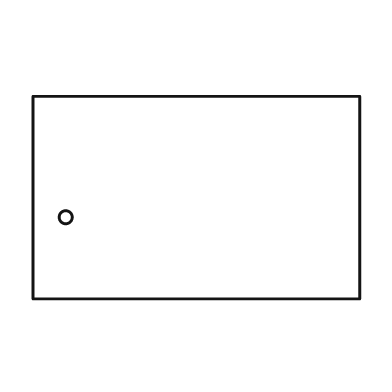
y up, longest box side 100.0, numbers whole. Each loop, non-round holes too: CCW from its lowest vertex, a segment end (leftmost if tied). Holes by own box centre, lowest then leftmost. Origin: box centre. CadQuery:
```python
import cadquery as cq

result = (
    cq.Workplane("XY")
    .moveTo(-50.0, -31.0)
    .lineTo(50.0, -31.0)
    .lineTo(50.0, 31.0)
    .lineTo(-50.0, 31.0)
    .close()
    .moveTo(-40.0, -6.0)
    .circle(2.0)
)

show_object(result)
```